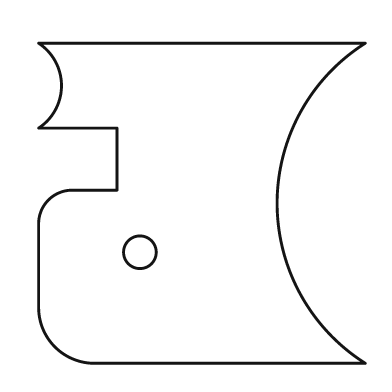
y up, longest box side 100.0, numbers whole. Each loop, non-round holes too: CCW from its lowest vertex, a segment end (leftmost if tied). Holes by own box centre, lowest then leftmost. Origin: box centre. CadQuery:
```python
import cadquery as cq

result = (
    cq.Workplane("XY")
    .moveTo(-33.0, -49.0)
    .lineTo(50.0, -49.0)
    .threePointArc((23.0, 0.0), (50.0, 49.0))
    .lineTo(-50.0, 49.0)
    .threePointArc((-43.0, 36.0), (-50.0, 23.0))
    .lineTo(-26.0, 23.0)
    .lineTo(-26.0, 4.0)
    .lineTo(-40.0, 4.0)
    .threePointArc((-47.0, 1.0), (-50.0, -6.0))
    .lineTo(-50.0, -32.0)
    .threePointArc((-45.0, -44.0), (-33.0, -49.0))
    .close()
    .moveTo(-19.0, -15.0)
    .circle(5.0)
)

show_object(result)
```